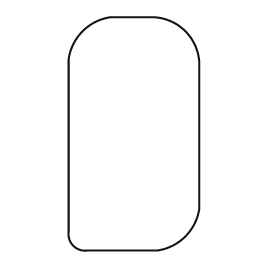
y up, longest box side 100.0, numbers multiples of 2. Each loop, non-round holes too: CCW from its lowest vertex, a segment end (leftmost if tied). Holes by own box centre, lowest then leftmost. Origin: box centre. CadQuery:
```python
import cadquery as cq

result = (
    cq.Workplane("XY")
    .moveTo(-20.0, -50.0)
    .lineTo(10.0, -50.0)
    .threePointArc((22.0, -44.0), (28.0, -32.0))
    .lineTo(28.0, 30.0)
    .threePointArc((22.0, 44.0), (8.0, 50.0))
    .lineTo(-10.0, 50.0)
    .threePointArc((-22.0, 44.0), (-28.0, 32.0))
    .lineTo(-28.0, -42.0)
    .threePointArc((-26.0, -48.0), (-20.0, -50.0))
    .close()
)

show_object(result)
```